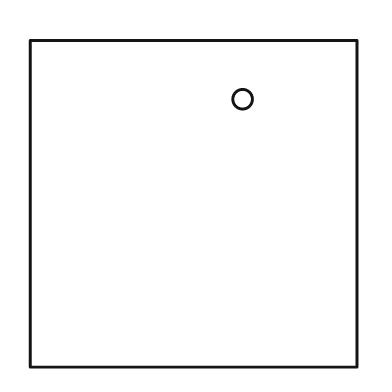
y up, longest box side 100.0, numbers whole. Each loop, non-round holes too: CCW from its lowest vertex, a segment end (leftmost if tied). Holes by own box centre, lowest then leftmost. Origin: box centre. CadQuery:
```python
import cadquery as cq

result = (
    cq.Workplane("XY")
    .moveTo(-50.0, -50.0)
    .lineTo(50.0, -50.0)
    .lineTo(50.0, 50.0)
    .lineTo(-50.0, 50.0)
    .close()
    .moveTo(15.0, 32.0)
    .circle(3.0)
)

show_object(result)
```